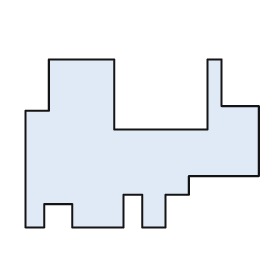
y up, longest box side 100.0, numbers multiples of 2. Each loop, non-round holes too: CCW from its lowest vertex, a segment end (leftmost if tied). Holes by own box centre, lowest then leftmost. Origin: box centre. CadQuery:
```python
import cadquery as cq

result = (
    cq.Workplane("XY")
    .moveTo(-50.0, -36.0)
    .lineTo(-42.0, -36.0)
    .lineTo(-42.0, -26.0)
    .lineTo(-30.0, -26.0)
    .lineTo(-30.0, -36.0)
    .lineTo(-8.0, -36.0)
    .lineTo(-8.0, -22.0)
    .lineTo(0.0, -22.0)
    .lineTo(0.0, -36.0)
    .lineTo(10.0, -36.0)
    .lineTo(10.0, -22.0)
    .lineTo(20.0, -22.0)
    .lineTo(20.0, -14.0)
    .lineTo(50.0, -14.0)
    .lineTo(50.0, 16.0)
    .lineTo(34.0, 16.0)
    .lineTo(34.0, 36.0)
    .lineTo(28.0, 36.0)
    .lineTo(28.0, 6.0)
    .lineTo(-12.0, 6.0)
    .lineTo(-12.0, 36.0)
    .lineTo(-40.0, 36.0)
    .lineTo(-40.0, 14.0)
    .lineTo(-50.0, 14.0)
    .close()
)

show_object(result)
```